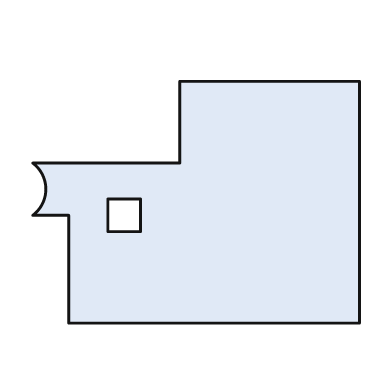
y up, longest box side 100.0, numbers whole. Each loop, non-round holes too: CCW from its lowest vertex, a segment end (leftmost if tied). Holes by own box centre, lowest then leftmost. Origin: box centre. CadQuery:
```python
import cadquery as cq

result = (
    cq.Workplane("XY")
    .moveTo(-39.0, -37.0)
    .lineTo(50.0, -37.0)
    .lineTo(50.0, 37.0)
    .lineTo(-5.0, 37.0)
    .lineTo(-5.0, 12.0)
    .lineTo(-50.0, 12.0)
    .threePointArc((-46.0, 4.0), (-50.0, -4.0))
    .lineTo(-39.0, -4.0)
    .close()
    .moveTo(-27.0, -9.0)
    .lineTo(-17.0, -9.0)
    .lineTo(-17.0, 1.0)
    .lineTo(-27.0, 1.0)
    .close()
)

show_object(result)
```